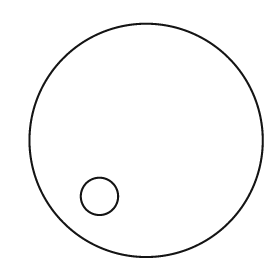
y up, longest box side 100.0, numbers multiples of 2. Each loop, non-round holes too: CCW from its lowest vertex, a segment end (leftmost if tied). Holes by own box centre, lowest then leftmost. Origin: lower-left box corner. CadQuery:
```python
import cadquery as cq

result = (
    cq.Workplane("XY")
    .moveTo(50.0, 50.0)
    .circle(50.0)
    .moveTo(30.0, 26.0)
    .circle(8.0)
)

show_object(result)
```